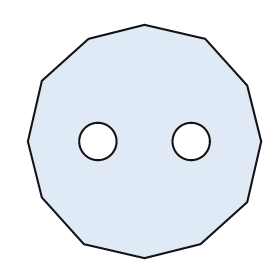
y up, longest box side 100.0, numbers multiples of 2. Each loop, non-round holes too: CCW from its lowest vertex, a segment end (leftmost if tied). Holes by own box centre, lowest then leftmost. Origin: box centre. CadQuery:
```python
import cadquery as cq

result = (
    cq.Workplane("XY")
    .moveTo(0.0, -50.0)
    .lineTo(24.0, -44.0)
    .lineTo(44.0, -26.0)
    .lineTo(50.0, 0.0)
    .lineTo(44.0, 24.0)
    .lineTo(26.0, 44.0)
    .lineTo(0.0, 50.0)
    .lineTo(-24.0, 44.0)
    .lineTo(-44.0, 26.0)
    .lineTo(-50.0, 0.0)
    .lineTo(-44.0, -24.0)
    .lineTo(-26.0, -44.0)
    .close()
    .moveTo(-20.0, 0.0)
    .circle(8.0)
    .moveTo(20.0, 0.0)
    .circle(8.0)
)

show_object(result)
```